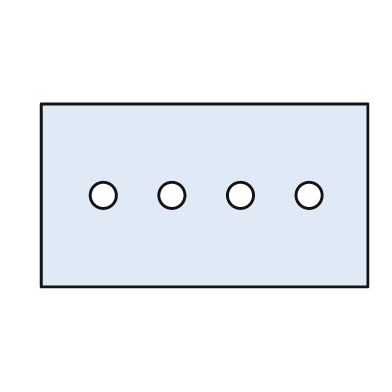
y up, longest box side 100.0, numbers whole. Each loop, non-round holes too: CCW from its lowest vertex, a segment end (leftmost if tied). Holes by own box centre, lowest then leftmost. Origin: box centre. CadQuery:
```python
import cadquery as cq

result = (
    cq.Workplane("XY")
    .moveTo(-50.0, -28.0)
    .lineTo(50.0, -28.0)
    .lineTo(50.0, 28.0)
    .lineTo(-50.0, 28.0)
    .close()
    .moveTo(-31.0, 0.0)
    .circle(4.0)
    .moveTo(-10.0, 0.0)
    .circle(4.0)
    .moveTo(11.0, 0.0)
    .circle(4.0)
    .moveTo(32.0, 0.0)
    .circle(4.0)
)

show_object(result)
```